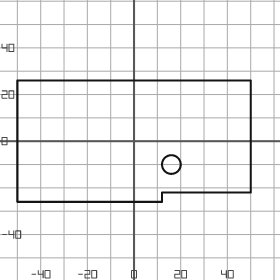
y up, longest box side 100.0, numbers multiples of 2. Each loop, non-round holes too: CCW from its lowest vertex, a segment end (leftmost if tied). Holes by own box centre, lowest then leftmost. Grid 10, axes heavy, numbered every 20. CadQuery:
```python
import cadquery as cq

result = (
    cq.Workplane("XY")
    .moveTo(-50.0, -26.0)
    .lineTo(12.0, -26.0)
    .lineTo(12.0, -22.0)
    .lineTo(50.0, -22.0)
    .lineTo(50.0, 26.0)
    .lineTo(-50.0, 26.0)
    .close()
    .moveTo(16.0, -10.0)
    .circle(4.0)
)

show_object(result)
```